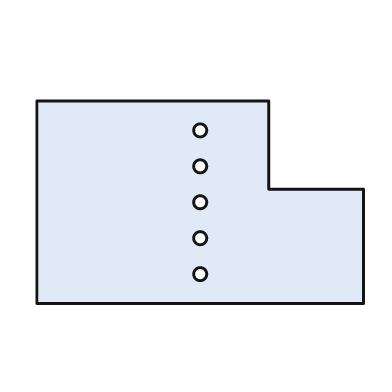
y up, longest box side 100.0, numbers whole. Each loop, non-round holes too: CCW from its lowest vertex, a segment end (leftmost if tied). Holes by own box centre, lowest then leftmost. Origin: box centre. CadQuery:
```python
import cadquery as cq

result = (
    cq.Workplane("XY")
    .moveTo(-50.0, -31.0)
    .lineTo(50.0, -31.0)
    .lineTo(50.0, 4.0)
    .lineTo(21.0, 4.0)
    .lineTo(21.0, 31.0)
    .lineTo(-50.0, 31.0)
    .close()
    .moveTo(0.0, -22.0)
    .circle(2.0)
    .moveTo(0.0, -11.0)
    .circle(2.0)
    .moveTo(0.0, 0.0)
    .circle(2.0)
    .moveTo(0.0, 11.0)
    .circle(2.0)
    .moveTo(0.0, 22.0)
    .circle(2.0)
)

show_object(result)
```